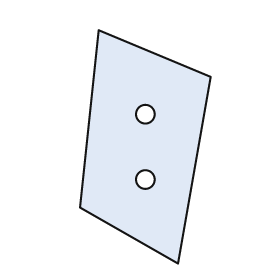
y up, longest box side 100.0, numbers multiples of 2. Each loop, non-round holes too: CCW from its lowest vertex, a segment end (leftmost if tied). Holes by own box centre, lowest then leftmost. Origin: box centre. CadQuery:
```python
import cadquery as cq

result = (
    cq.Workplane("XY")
    .moveTo(14.0, -50.0)
    .lineTo(28.0, 30.0)
    .lineTo(-20.0, 50.0)
    .lineTo(-28.0, -26.0)
    .close()
    .moveTo(0.0, -14.0)
    .circle(4.0)
    .moveTo(0.0, 14.0)
    .circle(4.0)
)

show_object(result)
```